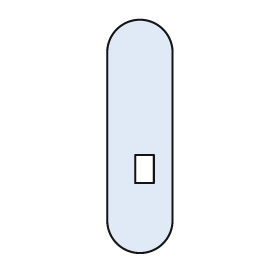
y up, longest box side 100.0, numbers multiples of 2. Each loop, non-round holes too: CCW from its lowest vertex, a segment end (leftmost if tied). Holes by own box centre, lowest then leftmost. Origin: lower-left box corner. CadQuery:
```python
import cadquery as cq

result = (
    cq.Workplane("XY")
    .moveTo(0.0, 14.0)
    .threePointArc((14.0, 0.0), (28.0, 14.0))
    .lineTo(28.0, 86.0)
    .threePointArc((14.0, 100.0), (0.0, 86.0))
    .close()
    .moveTo(12.0, 30.0)
    .lineTo(20.0, 30.0)
    .lineTo(20.0, 42.0)
    .lineTo(12.0, 42.0)
    .close()
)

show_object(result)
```